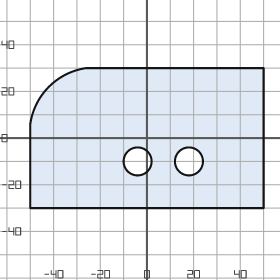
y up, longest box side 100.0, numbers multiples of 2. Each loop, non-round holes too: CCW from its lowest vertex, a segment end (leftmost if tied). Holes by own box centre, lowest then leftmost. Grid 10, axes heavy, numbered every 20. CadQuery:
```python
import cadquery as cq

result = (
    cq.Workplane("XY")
    .moveTo(-50.0, -30.0)
    .lineTo(50.0, -30.0)
    .lineTo(50.0, 30.0)
    .lineTo(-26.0, 30.0)
    .threePointArc((-42.0, 22.0), (-50.0, 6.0))
    .close()
    .moveTo(-4.0, -10.0)
    .circle(6.0)
    .moveTo(18.0, -10.0)
    .circle(6.0)
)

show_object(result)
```